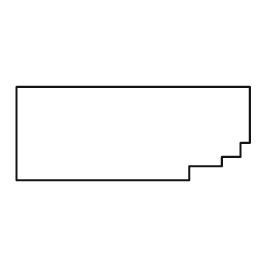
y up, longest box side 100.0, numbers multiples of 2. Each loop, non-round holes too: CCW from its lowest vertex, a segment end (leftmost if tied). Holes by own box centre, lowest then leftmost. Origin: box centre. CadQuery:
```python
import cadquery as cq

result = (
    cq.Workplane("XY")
    .moveTo(-50.0, -20.0)
    .lineTo(24.0, -20.0)
    .lineTo(24.0, -14.0)
    .lineTo(38.0, -14.0)
    .lineTo(38.0, -10.0)
    .lineTo(46.0, -10.0)
    .lineTo(46.0, -4.0)
    .lineTo(50.0, -4.0)
    .lineTo(50.0, 20.0)
    .lineTo(-50.0, 20.0)
    .close()
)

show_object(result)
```